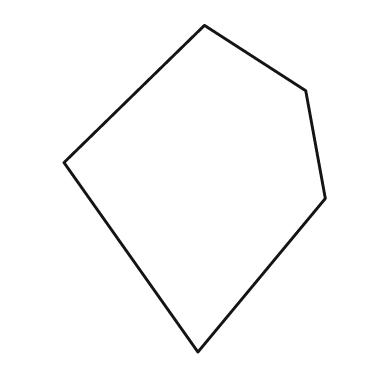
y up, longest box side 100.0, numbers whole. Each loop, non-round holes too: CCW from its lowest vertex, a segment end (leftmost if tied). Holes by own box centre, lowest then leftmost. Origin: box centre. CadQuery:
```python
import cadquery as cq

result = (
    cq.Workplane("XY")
    .moveTo(1.0, -50.0)
    .lineTo(40.0, -3.0)
    .lineTo(34.0, 30.0)
    .lineTo(3.0, 50.0)
    .lineTo(-40.0, 8.0)
    .close()
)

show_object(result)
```